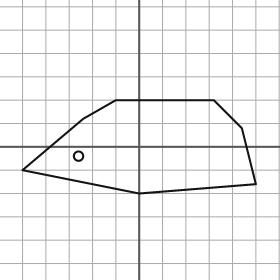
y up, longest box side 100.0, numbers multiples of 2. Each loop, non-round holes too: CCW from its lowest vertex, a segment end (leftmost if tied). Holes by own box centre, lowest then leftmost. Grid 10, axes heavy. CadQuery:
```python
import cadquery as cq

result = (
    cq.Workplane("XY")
    .moveTo(0.0, -20.0)
    .lineTo(50.0, -16.0)
    .lineTo(44.0, 8.0)
    .lineTo(32.0, 20.0)
    .lineTo(-10.0, 20.0)
    .lineTo(-24.0, 12.0)
    .lineTo(-50.0, -10.0)
    .close()
    .moveTo(-26.0, -4.0)
    .circle(2.0)
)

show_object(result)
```